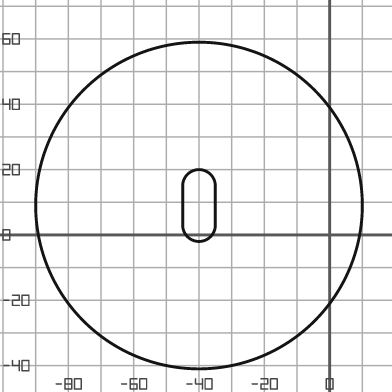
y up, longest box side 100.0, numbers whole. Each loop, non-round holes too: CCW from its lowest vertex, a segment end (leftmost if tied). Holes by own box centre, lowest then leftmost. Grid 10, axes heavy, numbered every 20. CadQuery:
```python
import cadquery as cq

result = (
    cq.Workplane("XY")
    .moveTo(-40.0, 9.0)
    .circle(50.0)
    .moveTo(-45.0, 3.0)
    .threePointArc((-40.0, -2.0), (-35.0, 3.0))
    .lineTo(-35.0, 15.0)
    .threePointArc((-40.0, 20.0), (-45.0, 15.0))
    .close()
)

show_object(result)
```